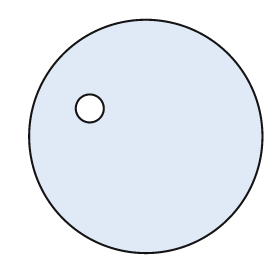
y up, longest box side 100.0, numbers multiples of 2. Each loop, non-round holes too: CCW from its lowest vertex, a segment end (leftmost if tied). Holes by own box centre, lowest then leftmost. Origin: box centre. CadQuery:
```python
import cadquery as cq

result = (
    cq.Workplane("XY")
    .moveTo(0.0, 0.0)
    .circle(50.0)
    .moveTo(-24.0, 12.0)
    .circle(6.0)
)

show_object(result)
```